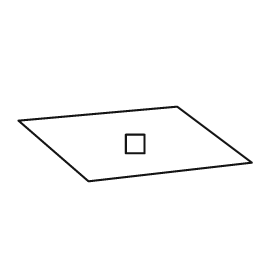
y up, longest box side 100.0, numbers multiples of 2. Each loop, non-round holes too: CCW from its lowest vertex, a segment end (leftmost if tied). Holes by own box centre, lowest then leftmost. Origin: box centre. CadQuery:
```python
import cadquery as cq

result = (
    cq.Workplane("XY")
    .moveTo(-20.0, -16.0)
    .lineTo(50.0, -8.0)
    .lineTo(18.0, 16.0)
    .lineTo(-50.0, 10.0)
    .close()
    .moveTo(-4.0, -4.0)
    .lineTo(4.0, -4.0)
    .lineTo(4.0, 4.0)
    .lineTo(-4.0, 4.0)
    .close()
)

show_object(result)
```